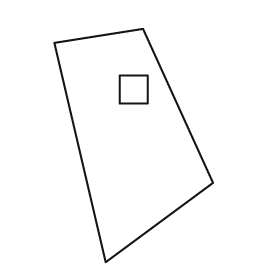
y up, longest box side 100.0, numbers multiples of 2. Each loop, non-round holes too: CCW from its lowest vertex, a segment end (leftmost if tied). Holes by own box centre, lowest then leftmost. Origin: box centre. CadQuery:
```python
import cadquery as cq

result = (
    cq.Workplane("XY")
    .moveTo(-12.0, -50.0)
    .lineTo(34.0, -16.0)
    .lineTo(4.0, 50.0)
    .lineTo(-34.0, 44.0)
    .close()
    .moveTo(-6.0, 18.0)
    .lineTo(6.0, 18.0)
    .lineTo(6.0, 30.0)
    .lineTo(-6.0, 30.0)
    .close()
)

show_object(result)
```